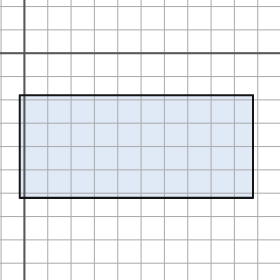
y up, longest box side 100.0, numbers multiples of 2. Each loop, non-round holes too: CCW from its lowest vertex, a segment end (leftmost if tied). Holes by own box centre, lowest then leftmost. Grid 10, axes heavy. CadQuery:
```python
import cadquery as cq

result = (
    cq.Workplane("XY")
    .moveTo(-2.0, -62.0)
    .lineTo(98.0, -62.0)
    .lineTo(98.0, -18.0)
    .lineTo(-2.0, -18.0)
    .close()
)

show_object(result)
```